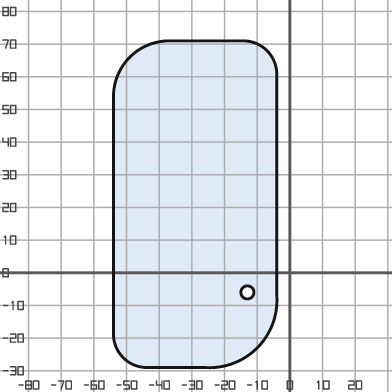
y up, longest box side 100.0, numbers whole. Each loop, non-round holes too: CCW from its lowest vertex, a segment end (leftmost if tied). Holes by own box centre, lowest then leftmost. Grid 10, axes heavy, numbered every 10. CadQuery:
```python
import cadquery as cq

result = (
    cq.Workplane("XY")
    .moveTo(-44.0, -29.0)
    .lineTo(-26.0, -29.0)
    .threePointArc((-10.0, -23.0), (-4.0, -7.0))
    .lineTo(-4.0, 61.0)
    .threePointArc((-7.0, 68.0), (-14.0, 71.0))
    .lineTo(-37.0, 71.0)
    .threePointArc((-49.0, 66.0), (-54.0, 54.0))
    .lineTo(-54.0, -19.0)
    .threePointArc((-51.0, -26.0), (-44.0, -29.0))
    .close()
    .moveTo(-13.0, -6.0)
    .circle(2.0)
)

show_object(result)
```